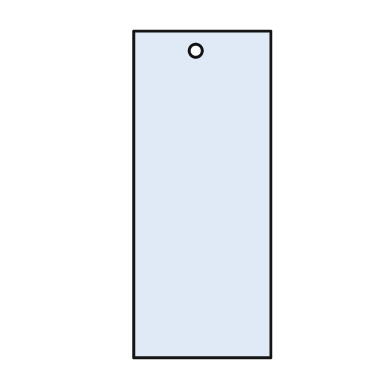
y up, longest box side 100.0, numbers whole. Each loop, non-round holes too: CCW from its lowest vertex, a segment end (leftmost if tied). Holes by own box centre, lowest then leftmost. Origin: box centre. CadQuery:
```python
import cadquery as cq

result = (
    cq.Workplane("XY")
    .moveTo(-21.0, -50.0)
    .lineTo(21.0, -50.0)
    .lineTo(21.0, 50.0)
    .lineTo(-21.0, 50.0)
    .close()
    .moveTo(-2.0, 44.0)
    .circle(2.0)
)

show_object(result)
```